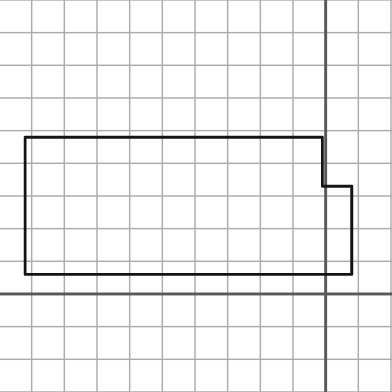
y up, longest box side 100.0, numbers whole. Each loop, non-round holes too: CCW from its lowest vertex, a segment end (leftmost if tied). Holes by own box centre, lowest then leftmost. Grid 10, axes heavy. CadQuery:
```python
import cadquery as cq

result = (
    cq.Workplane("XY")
    .moveTo(-92.0, 6.0)
    .lineTo(8.0, 6.0)
    .lineTo(8.0, 33.0)
    .lineTo(-1.0, 33.0)
    .lineTo(-1.0, 48.0)
    .lineTo(-92.0, 48.0)
    .close()
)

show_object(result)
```